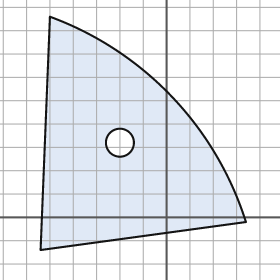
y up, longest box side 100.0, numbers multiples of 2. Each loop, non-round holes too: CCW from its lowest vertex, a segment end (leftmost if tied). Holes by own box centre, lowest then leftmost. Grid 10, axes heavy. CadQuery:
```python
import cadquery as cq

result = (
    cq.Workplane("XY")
    .moveTo(-54.0, -14.0)
    .lineTo(34.0, -2.0)
    .threePointArc((2.0, 52.0), (-50.0, 86.0))
    .close()
    .moveTo(-20.0, 32.0)
    .circle(6.0)
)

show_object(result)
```